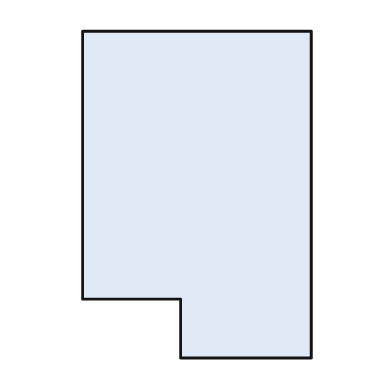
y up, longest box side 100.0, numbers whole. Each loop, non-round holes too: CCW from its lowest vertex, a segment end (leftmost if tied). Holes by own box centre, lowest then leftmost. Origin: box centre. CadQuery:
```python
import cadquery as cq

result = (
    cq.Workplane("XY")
    .moveTo(-5.0, -50.0)
    .lineTo(35.0, -50.0)
    .lineTo(35.0, 50.0)
    .lineTo(-35.0, 50.0)
    .lineTo(-35.0, -32.0)
    .lineTo(-5.0, -32.0)
    .close()
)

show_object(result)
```